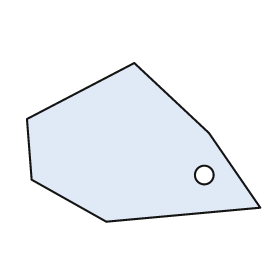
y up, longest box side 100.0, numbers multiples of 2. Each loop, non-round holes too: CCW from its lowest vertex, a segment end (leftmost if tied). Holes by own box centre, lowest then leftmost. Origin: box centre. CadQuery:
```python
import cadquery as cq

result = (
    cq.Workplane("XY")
    .moveTo(-16.0, -34.0)
    .lineTo(50.0, -28.0)
    .lineTo(28.0, 4.0)
    .lineTo(-4.0, 34.0)
    .lineTo(-50.0, 10.0)
    .lineTo(-48.0, -16.0)
    .close()
    .moveTo(26.0, -14.0)
    .circle(4.0)
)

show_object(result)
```